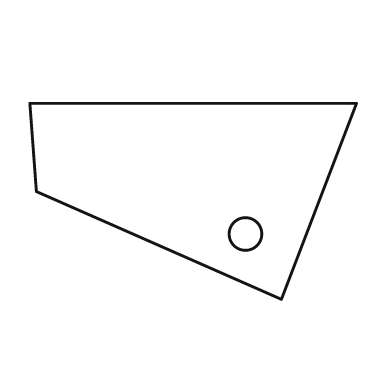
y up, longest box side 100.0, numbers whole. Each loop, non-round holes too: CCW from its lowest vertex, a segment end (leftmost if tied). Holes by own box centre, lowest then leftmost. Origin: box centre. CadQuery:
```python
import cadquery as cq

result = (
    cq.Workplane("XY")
    .moveTo(27.0, -30.0)
    .lineTo(50.0, 30.0)
    .lineTo(-50.0, 30.0)
    .lineTo(-48.0, 3.0)
    .close()
    .moveTo(16.0, -10.0)
    .circle(5.0)
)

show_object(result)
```